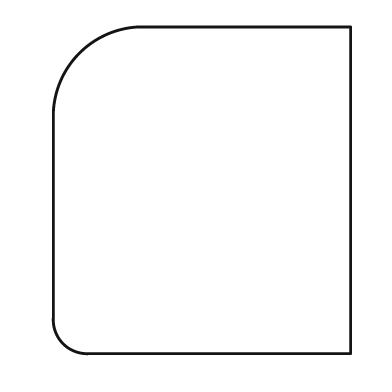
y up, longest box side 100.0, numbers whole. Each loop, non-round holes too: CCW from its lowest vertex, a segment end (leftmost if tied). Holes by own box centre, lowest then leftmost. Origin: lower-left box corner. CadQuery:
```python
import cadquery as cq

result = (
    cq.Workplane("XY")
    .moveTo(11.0, 0.0)
    .lineTo(91.0, 0.0)
    .lineTo(91.0, 100.0)
    .lineTo(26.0, 100.0)
    .threePointArc((8.0, 92.0), (0.0, 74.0))
    .lineTo(0.0, 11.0)
    .threePointArc((3.0, 3.0), (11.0, 0.0))
    .close()
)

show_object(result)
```